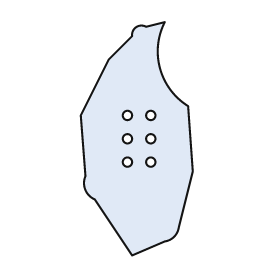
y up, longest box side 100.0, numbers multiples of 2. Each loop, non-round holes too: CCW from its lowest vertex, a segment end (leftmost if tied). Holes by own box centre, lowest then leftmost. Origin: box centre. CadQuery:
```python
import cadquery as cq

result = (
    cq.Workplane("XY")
    .moveTo(-2.0, -50.0)
    .lineTo(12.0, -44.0)
    .threePointArc((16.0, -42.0), (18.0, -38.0))
    .lineTo(24.0, -14.0)
    .lineTo(22.0, 14.0)
    .threePointArc((10.0, 30.0), (12.0, 50.0))
    .lineTo(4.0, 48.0)
    .threePointArc((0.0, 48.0), (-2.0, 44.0))
    .lineTo(-12.0, 34.0)
    .lineTo(-24.0, 10.0)
    .lineTo(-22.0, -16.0)
    .threePointArc((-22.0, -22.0), (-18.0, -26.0))
    .close()
    .moveTo(-4.0, -10.0)
    .circle(2.0)
    .moveTo(6.0, -10.0)
    .circle(2.0)
    .moveTo(-4.0, 0.0)
    .circle(2.0)
    .moveTo(6.0, 0.0)
    .circle(2.0)
    .moveTo(-4.0, 10.0)
    .circle(2.0)
    .moveTo(6.0, 10.0)
    .circle(2.0)
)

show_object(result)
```